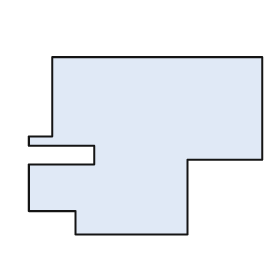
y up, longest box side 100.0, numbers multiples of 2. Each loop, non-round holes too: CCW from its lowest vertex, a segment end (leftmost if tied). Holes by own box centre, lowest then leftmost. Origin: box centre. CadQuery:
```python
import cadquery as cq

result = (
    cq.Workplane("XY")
    .moveTo(-30.0, -38.0)
    .lineTo(18.0, -38.0)
    .lineTo(18.0, -6.0)
    .lineTo(50.0, -6.0)
    .lineTo(50.0, 38.0)
    .lineTo(-40.0, 38.0)
    .lineTo(-40.0, 4.0)
    .lineTo(-50.0, 4.0)
    .lineTo(-50.0, 0.0)
    .lineTo(-22.0, 0.0)
    .lineTo(-22.0, -8.0)
    .lineTo(-50.0, -8.0)
    .lineTo(-50.0, -28.0)
    .lineTo(-30.0, -28.0)
    .close()
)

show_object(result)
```